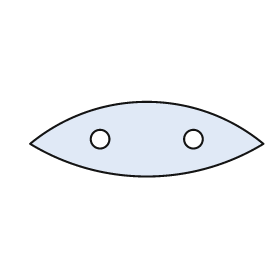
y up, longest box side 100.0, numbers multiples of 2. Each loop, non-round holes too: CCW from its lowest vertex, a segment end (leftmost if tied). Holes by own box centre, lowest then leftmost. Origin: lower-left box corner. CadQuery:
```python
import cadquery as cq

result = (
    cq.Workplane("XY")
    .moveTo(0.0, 14.0)
    .threePointArc((50.0, 0.0), (100.0, 14.0))
    .threePointArc((50.0, 32.0), (0.0, 14.0))
    .close()
    .moveTo(30.0, 16.0)
    .circle(4.0)
    .moveTo(70.0, 16.0)
    .circle(4.0)
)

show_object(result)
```